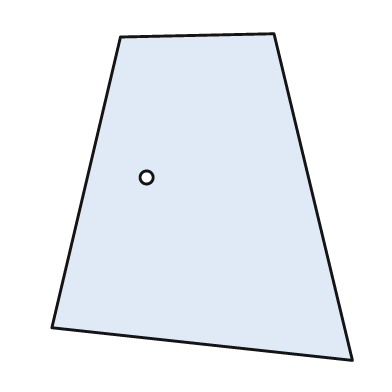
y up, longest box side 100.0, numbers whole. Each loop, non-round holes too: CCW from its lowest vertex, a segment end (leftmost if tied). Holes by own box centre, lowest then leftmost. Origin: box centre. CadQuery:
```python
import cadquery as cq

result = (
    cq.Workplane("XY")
    .moveTo(46.0, -50.0)
    .lineTo(22.0, 50.0)
    .lineTo(-25.0, 49.0)
    .lineTo(-46.0, -40.0)
    .close()
    .moveTo(-17.0, 6.0)
    .circle(2.0)
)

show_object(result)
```